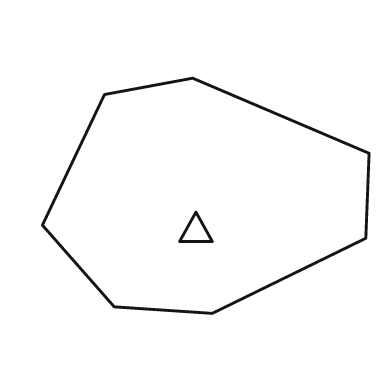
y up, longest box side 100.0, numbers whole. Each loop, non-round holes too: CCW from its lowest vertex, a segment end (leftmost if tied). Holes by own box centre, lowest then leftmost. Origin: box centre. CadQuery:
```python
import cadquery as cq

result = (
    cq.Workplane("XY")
    .moveTo(2.0, -36.0)
    .lineTo(49.0, -13.0)
    .lineTo(50.0, 13.0)
    .lineTo(-4.0, 36.0)
    .lineTo(-31.0, 31.0)
    .lineTo(-50.0, -9.0)
    .lineTo(-28.0, -34.0)
    .close()
    .moveTo(-8.0, -14.0)
    .lineTo(2.0, -14.0)
    .lineTo(-3.0, -5.0)
    .close()
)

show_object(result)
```